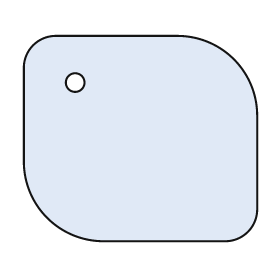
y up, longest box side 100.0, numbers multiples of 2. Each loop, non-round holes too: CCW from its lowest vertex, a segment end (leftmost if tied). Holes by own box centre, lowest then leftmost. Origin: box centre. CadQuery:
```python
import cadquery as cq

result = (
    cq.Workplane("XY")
    .moveTo(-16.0, -44.0)
    .lineTo(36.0, -44.0)
    .threePointArc((46.0, -40.0), (50.0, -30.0))
    .lineTo(50.0, 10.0)
    .threePointArc((40.0, 34.0), (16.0, 44.0))
    .lineTo(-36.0, 44.0)
    .threePointArc((-46.0, 40.0), (-50.0, 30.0))
    .lineTo(-50.0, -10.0)
    .threePointArc((-40.0, -34.0), (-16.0, -44.0))
    .close()
    .moveTo(-28.0, 24.0)
    .circle(4.0)
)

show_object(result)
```